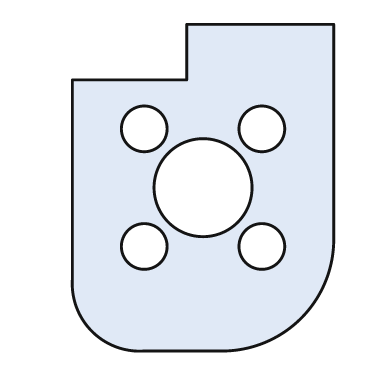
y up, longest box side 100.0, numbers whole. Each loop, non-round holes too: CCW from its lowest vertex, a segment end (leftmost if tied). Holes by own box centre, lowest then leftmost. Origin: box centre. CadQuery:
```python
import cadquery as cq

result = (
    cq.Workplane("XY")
    .moveTo(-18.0, -50.0)
    .lineTo(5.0, -50.0)
    .threePointArc((30.0, -40.0), (40.0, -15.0))
    .lineTo(40.0, 50.0)
    .lineTo(-5.0, 50.0)
    .lineTo(-5.0, 33.0)
    .lineTo(-40.0, 33.0)
    .lineTo(-40.0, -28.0)
    .threePointArc((-34.0, -44.0), (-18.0, -50.0))
    .close()
    .moveTo(-18.0, -18.0)
    .circle(7.0)
    .moveTo(18.0, -18.0)
    .circle(7.0)
    .moveTo(0.0, 0.0)
    .circle(15.0)
    .moveTo(-18.0, 18.0)
    .circle(7.0)
    .moveTo(18.0, 18.0)
    .circle(7.0)
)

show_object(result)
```